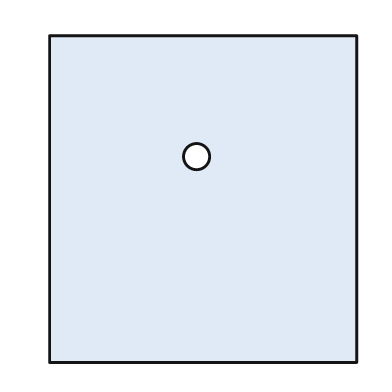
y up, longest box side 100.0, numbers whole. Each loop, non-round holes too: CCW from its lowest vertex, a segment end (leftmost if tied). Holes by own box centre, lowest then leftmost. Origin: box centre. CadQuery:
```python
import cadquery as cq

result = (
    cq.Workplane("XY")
    .moveTo(-47.0, -50.0)
    .lineTo(47.0, -50.0)
    .lineTo(47.0, 50.0)
    .lineTo(-47.0, 50.0)
    .close()
    .moveTo(-2.0, 13.0)
    .circle(4.0)
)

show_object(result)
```